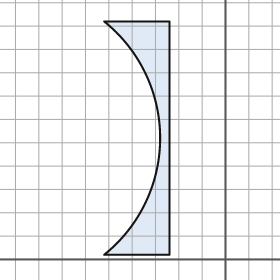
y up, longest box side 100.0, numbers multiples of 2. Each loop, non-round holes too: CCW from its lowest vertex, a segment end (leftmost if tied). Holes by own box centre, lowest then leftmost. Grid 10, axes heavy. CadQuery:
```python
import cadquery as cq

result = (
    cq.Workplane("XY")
    .moveTo(-52.0, 2.0)
    .lineTo(-24.0, 2.0)
    .lineTo(-24.0, 102.0)
    .lineTo(-52.0, 102.0)
    .threePointArc((-28.0, 52.0), (-52.0, 2.0))
    .close()
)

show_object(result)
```